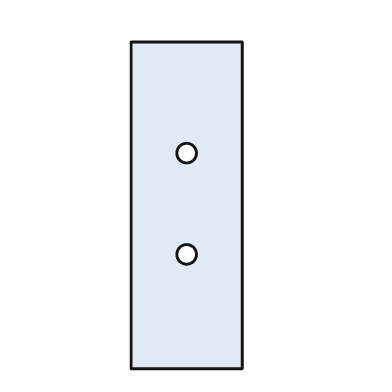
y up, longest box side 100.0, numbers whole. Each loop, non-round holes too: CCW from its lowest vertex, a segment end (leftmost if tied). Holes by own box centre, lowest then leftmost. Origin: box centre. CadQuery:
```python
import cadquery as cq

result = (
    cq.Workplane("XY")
    .moveTo(-17.0, -50.0)
    .lineTo(17.0, -50.0)
    .lineTo(17.0, 50.0)
    .lineTo(-17.0, 50.0)
    .close()
    .moveTo(0.0, -15.0)
    .circle(3.0)
    .moveTo(0.0, 16.0)
    .circle(3.0)
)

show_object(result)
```